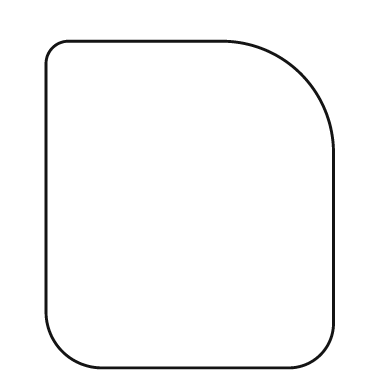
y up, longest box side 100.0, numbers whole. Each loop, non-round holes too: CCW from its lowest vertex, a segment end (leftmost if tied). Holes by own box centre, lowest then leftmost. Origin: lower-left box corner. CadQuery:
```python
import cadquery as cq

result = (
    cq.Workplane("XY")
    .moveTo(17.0, 0.0)
    .lineTo(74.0, 0.0)
    .threePointArc((84.0, 4.0), (88.0, 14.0))
    .lineTo(88.0, 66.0)
    .threePointArc((78.0, 90.0), (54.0, 100.0))
    .lineTo(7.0, 100.0)
    .threePointArc((2.0, 98.0), (0.0, 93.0))
    .lineTo(0.0, 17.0)
    .threePointArc((5.0, 5.0), (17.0, 0.0))
    .close()
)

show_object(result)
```